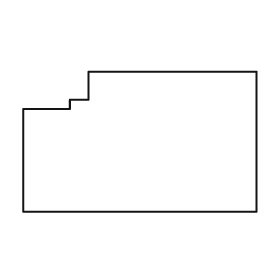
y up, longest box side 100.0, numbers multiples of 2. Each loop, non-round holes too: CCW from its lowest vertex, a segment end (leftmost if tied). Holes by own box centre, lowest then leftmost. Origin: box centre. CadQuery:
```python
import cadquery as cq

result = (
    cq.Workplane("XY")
    .moveTo(-50.0, -30.0)
    .lineTo(50.0, -30.0)
    .lineTo(50.0, 30.0)
    .lineTo(-22.0, 30.0)
    .lineTo(-22.0, 18.0)
    .lineTo(-30.0, 18.0)
    .lineTo(-30.0, 14.0)
    .lineTo(-50.0, 14.0)
    .close()
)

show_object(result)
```